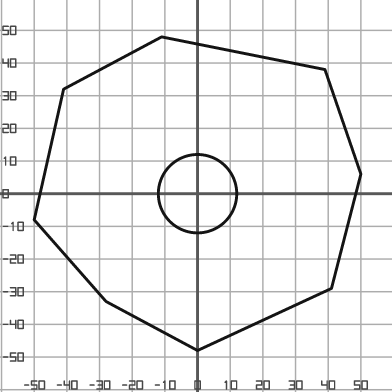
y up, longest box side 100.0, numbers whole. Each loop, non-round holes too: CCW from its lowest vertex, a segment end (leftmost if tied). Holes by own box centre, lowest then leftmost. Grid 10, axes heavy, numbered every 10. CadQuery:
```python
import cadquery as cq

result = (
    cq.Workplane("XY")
    .moveTo(0.0, -48.0)
    .lineTo(41.0, -29.0)
    .lineTo(50.0, 6.0)
    .lineTo(39.0, 38.0)
    .lineTo(-11.0, 48.0)
    .lineTo(-41.0, 32.0)
    .lineTo(-50.0, -8.0)
    .lineTo(-28.0, -33.0)
    .close()
    .moveTo(0.0, 0.0)
    .circle(12.0)
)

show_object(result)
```